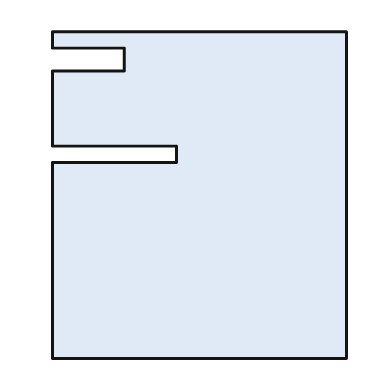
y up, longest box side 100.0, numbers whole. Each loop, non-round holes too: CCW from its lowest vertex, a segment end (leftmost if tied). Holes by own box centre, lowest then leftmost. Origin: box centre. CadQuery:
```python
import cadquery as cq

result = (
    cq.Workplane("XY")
    .moveTo(-45.0, -50.0)
    .lineTo(45.0, -50.0)
    .lineTo(45.0, 50.0)
    .lineTo(-45.0, 50.0)
    .lineTo(-45.0, 45.0)
    .lineTo(-23.0, 45.0)
    .lineTo(-23.0, 38.0)
    .lineTo(-45.0, 38.0)
    .lineTo(-45.0, 15.0)
    .lineTo(-7.0, 15.0)
    .lineTo(-7.0, 10.0)
    .lineTo(-45.0, 10.0)
    .close()
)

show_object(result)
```